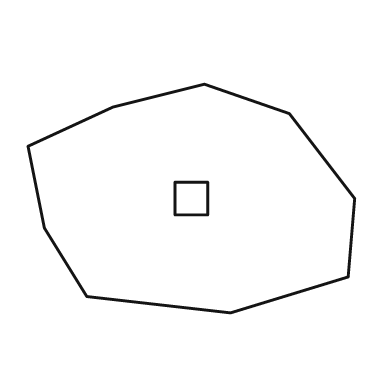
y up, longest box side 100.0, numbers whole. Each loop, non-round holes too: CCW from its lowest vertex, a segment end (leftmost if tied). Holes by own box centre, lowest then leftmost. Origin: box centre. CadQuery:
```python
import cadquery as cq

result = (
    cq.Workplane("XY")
    .moveTo(12.0, -35.0)
    .lineTo(48.0, -24.0)
    .lineTo(50.0, 0.0)
    .lineTo(30.0, 26.0)
    .lineTo(4.0, 35.0)
    .lineTo(-24.0, 28.0)
    .lineTo(-50.0, 16.0)
    .lineTo(-45.0, -9.0)
    .lineTo(-32.0, -30.0)
    .close()
    .moveTo(-5.0, -5.0)
    .lineTo(5.0, -5.0)
    .lineTo(5.0, 5.0)
    .lineTo(-5.0, 5.0)
    .close()
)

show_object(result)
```